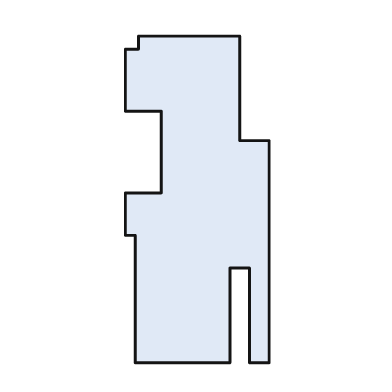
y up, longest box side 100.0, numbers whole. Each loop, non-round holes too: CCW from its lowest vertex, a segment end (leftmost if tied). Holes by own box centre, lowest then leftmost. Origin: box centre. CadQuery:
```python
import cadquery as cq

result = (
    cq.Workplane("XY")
    .moveTo(-19.0, -50.0)
    .lineTo(10.0, -50.0)
    .lineTo(10.0, -21.0)
    .lineTo(16.0, -21.0)
    .lineTo(16.0, -50.0)
    .lineTo(22.0, -50.0)
    .lineTo(22.0, 18.0)
    .lineTo(13.0, 18.0)
    .lineTo(13.0, 50.0)
    .lineTo(-18.0, 50.0)
    .lineTo(-18.0, 46.0)
    .lineTo(-22.0, 46.0)
    .lineTo(-22.0, 27.0)
    .lineTo(-11.0, 27.0)
    .lineTo(-11.0, 2.0)
    .lineTo(-22.0, 2.0)
    .lineTo(-22.0, -11.0)
    .lineTo(-19.0, -11.0)
    .close()
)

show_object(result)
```